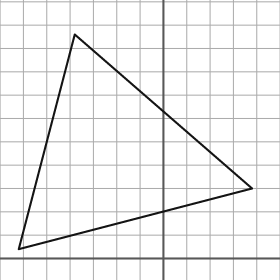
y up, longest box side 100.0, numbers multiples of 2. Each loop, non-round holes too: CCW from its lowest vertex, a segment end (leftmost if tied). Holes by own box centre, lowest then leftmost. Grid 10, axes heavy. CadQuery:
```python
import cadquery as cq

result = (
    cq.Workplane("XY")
    .moveTo(-62.0, 4.0)
    .lineTo(38.0, 30.0)
    .lineTo(-38.0, 96.0)
    .close()
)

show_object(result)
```